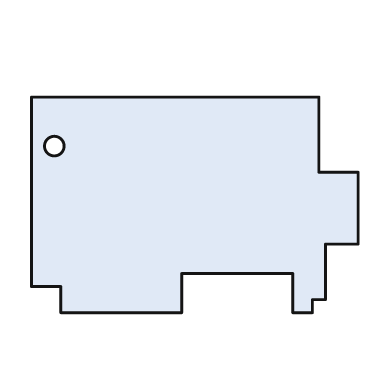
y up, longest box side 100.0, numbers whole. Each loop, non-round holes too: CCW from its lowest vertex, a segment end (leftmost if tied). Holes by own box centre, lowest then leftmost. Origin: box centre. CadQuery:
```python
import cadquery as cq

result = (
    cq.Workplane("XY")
    .moveTo(-41.0, -33.0)
    .lineTo(-4.0, -33.0)
    .lineTo(-4.0, -21.0)
    .lineTo(30.0, -21.0)
    .lineTo(30.0, -33.0)
    .lineTo(36.0, -33.0)
    .lineTo(36.0, -29.0)
    .lineTo(40.0, -29.0)
    .lineTo(40.0, -12.0)
    .lineTo(50.0, -12.0)
    .lineTo(50.0, 10.0)
    .lineTo(38.0, 10.0)
    .lineTo(38.0, 33.0)
    .lineTo(-50.0, 33.0)
    .lineTo(-50.0, -25.0)
    .lineTo(-41.0, -25.0)
    .close()
    .moveTo(-43.0, 18.0)
    .circle(3.0)
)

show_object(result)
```